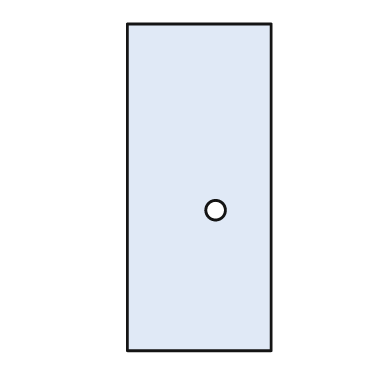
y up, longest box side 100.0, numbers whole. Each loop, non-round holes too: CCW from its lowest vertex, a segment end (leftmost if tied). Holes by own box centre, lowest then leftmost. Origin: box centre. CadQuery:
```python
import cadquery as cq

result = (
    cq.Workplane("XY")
    .moveTo(-22.0, -50.0)
    .lineTo(22.0, -50.0)
    .lineTo(22.0, 50.0)
    .lineTo(-22.0, 50.0)
    .close()
    .moveTo(5.0, -7.0)
    .circle(3.0)
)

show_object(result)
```